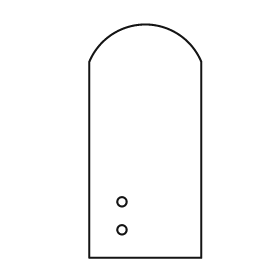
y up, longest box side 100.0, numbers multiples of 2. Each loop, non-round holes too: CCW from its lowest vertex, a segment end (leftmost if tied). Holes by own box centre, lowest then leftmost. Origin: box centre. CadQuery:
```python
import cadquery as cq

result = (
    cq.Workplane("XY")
    .moveTo(-24.0, -50.0)
    .lineTo(24.0, -50.0)
    .lineTo(24.0, 34.0)
    .threePointArc((0.0, 50.0), (-24.0, 34.0))
    .close()
    .moveTo(-10.0, -38.0)
    .circle(2.0)
    .moveTo(-10.0, -26.0)
    .circle(2.0)
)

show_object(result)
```